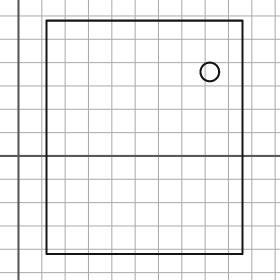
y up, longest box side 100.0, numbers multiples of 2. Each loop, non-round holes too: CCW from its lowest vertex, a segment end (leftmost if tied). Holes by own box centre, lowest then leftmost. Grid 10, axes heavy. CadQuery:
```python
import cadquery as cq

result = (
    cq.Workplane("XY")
    .moveTo(12.0, -42.0)
    .lineTo(96.0, -42.0)
    .lineTo(96.0, 58.0)
    .lineTo(12.0, 58.0)
    .close()
    .moveTo(82.0, 36.0)
    .circle(4.0)
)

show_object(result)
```